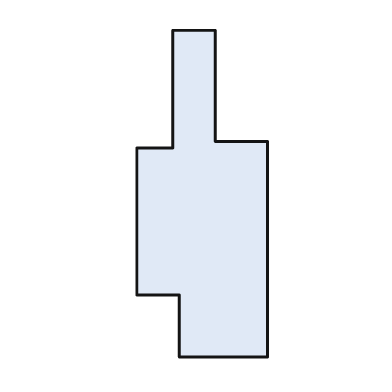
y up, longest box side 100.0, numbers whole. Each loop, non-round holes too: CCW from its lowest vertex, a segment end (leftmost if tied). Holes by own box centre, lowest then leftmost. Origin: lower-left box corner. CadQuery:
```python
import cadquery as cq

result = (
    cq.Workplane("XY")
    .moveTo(13.0, 0.0)
    .lineTo(40.0, 0.0)
    .lineTo(40.0, 66.0)
    .lineTo(24.0, 66.0)
    .lineTo(24.0, 100.0)
    .lineTo(11.0, 100.0)
    .lineTo(11.0, 64.0)
    .lineTo(0.0, 64.0)
    .lineTo(0.0, 19.0)
    .lineTo(13.0, 19.0)
    .close()
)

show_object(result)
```